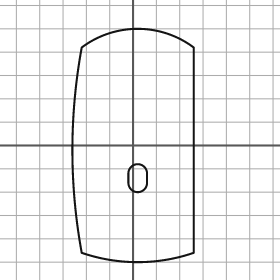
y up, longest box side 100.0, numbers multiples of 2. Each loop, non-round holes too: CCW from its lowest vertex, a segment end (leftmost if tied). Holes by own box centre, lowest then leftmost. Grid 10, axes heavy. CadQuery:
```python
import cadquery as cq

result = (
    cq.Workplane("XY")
    .moveTo(-22.0, -46.0)
    .threePointArc((2.0, -50.0), (26.0, -46.0))
    .lineTo(26.0, 42.0)
    .threePointArc((2.0, 50.0), (-22.0, 42.0))
    .threePointArc((-26.0, -2.0), (-22.0, -46.0))
    .close()
    .moveTo(-2.0, -16.0)
    .threePointArc((2.0, -20.0), (6.0, -16.0))
    .lineTo(6.0, -12.0)
    .threePointArc((2.0, -8.0), (-2.0, -12.0))
    .close()
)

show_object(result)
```